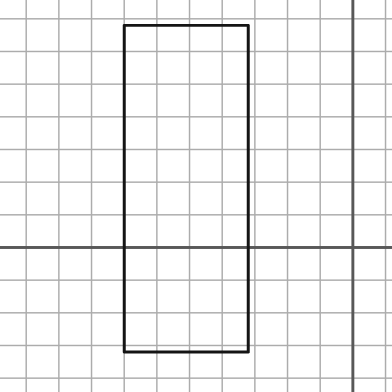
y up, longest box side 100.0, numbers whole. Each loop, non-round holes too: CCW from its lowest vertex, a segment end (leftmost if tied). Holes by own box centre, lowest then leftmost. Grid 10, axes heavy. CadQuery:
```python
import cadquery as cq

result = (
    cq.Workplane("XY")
    .moveTo(-70.0, -32.0)
    .lineTo(-32.0, -32.0)
    .lineTo(-32.0, 68.0)
    .lineTo(-70.0, 68.0)
    .close()
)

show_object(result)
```